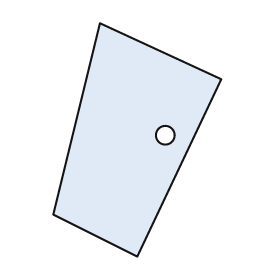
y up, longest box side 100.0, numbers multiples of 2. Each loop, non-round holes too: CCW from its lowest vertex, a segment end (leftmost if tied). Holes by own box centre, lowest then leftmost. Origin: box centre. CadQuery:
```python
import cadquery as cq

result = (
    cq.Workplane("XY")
    .moveTo(0.0, -50.0)
    .lineTo(36.0, 26.0)
    .lineTo(-16.0, 50.0)
    .lineTo(-36.0, -32.0)
    .close()
    .moveTo(12.0, 2.0)
    .circle(4.0)
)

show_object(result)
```